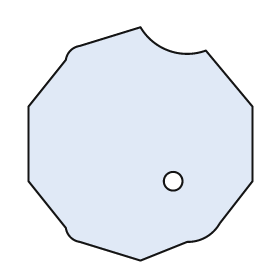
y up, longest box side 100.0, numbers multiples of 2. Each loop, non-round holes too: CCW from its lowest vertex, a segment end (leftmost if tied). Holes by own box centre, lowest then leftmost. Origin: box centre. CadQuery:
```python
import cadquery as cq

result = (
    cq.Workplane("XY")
    .moveTo(0.0, -50.0)
    .lineTo(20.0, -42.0)
    .threePointArc((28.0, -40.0), (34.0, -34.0))
    .lineTo(48.0, -16.0)
    .lineTo(48.0, 16.0)
    .lineTo(28.0, 40.0)
    .threePointArc((12.0, 40.0), (0.0, 50.0))
    .lineTo(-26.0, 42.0)
    .threePointArc((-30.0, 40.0), (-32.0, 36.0))
    .lineTo(-48.0, 16.0)
    .lineTo(-48.0, -16.0)
    .lineTo(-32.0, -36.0)
    .threePointArc((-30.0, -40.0), (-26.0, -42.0))
    .close()
    .moveTo(14.0, -16.0)
    .circle(4.0)
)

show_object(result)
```